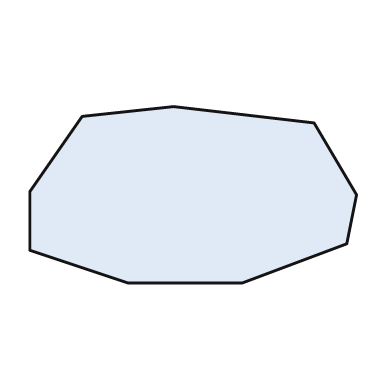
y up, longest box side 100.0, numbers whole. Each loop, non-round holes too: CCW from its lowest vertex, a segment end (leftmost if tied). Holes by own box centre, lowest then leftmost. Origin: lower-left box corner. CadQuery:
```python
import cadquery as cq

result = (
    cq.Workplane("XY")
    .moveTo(30.0, 0.0)
    .lineTo(65.0, 0.0)
    .lineTo(97.0, 12.0)
    .lineTo(100.0, 27.0)
    .lineTo(87.0, 49.0)
    .lineTo(44.0, 54.0)
    .lineTo(16.0, 51.0)
    .lineTo(0.0, 28.0)
    .lineTo(0.0, 10.0)
    .close()
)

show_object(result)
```